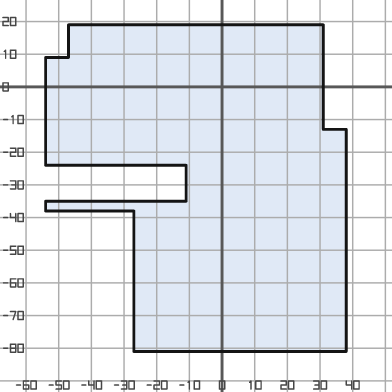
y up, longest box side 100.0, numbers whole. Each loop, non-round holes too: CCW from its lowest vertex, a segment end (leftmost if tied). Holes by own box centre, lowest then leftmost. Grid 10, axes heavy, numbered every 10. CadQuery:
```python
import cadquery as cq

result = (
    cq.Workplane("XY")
    .moveTo(-27.0, -81.0)
    .lineTo(38.0, -81.0)
    .lineTo(38.0, -13.0)
    .lineTo(31.0, -13.0)
    .lineTo(31.0, 19.0)
    .lineTo(-47.0, 19.0)
    .lineTo(-47.0, 9.0)
    .lineTo(-54.0, 9.0)
    .lineTo(-54.0, -24.0)
    .lineTo(-11.0, -24.0)
    .lineTo(-11.0, -35.0)
    .lineTo(-54.0, -35.0)
    .lineTo(-54.0, -38.0)
    .lineTo(-27.0, -38.0)
    .close()
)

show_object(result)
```